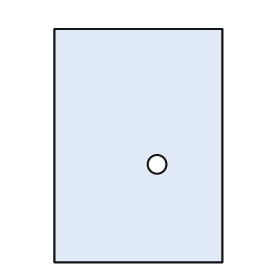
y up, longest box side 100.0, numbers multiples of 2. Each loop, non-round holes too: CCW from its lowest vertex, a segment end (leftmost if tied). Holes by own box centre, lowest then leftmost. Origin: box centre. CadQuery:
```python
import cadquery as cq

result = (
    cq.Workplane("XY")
    .moveTo(-36.0, -50.0)
    .lineTo(36.0, -50.0)
    .lineTo(36.0, 50.0)
    .lineTo(-36.0, 50.0)
    .close()
    .moveTo(8.0, -8.0)
    .circle(4.0)
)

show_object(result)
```